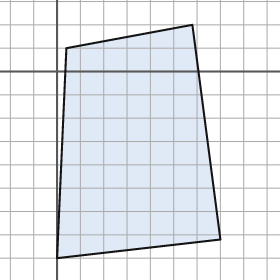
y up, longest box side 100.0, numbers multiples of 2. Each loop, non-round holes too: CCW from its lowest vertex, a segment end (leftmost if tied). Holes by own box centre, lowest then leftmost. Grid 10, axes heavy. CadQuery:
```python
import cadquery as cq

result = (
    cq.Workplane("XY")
    .moveTo(0.0, -80.0)
    .lineTo(70.0, -72.0)
    .lineTo(58.0, 20.0)
    .lineTo(4.0, 10.0)
    .close()
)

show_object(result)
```